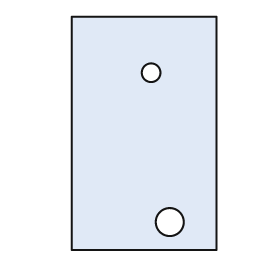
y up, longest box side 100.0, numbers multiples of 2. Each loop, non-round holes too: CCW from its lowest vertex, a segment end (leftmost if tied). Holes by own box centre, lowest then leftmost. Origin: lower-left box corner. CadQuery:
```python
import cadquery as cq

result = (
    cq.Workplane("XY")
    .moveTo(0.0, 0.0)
    .lineTo(62.0, 0.0)
    .lineTo(62.0, 100.0)
    .lineTo(0.0, 100.0)
    .close()
    .moveTo(42.0, 12.0)
    .circle(6.0)
    .moveTo(34.0, 76.0)
    .circle(4.0)
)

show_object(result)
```